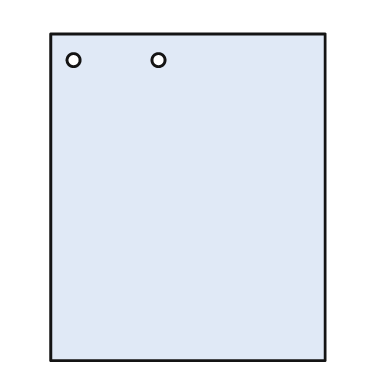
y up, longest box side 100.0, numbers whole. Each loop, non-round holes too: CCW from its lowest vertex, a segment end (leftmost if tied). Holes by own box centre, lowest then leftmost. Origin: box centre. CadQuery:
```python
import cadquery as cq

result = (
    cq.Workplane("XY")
    .moveTo(-42.0, -50.0)
    .lineTo(42.0, -50.0)
    .lineTo(42.0, 50.0)
    .lineTo(-42.0, 50.0)
    .close()
    .moveTo(-35.0, 42.0)
    .circle(2.0)
    .moveTo(-9.0, 42.0)
    .circle(2.0)
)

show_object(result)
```